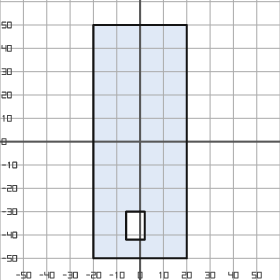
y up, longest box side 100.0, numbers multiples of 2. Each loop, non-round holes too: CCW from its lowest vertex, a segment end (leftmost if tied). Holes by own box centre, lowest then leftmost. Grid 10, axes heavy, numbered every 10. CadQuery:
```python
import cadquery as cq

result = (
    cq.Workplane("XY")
    .moveTo(-20.0, -50.0)
    .lineTo(20.0, -50.0)
    .lineTo(20.0, 50.0)
    .lineTo(-20.0, 50.0)
    .close()
    .moveTo(-6.0, -42.0)
    .lineTo(2.0, -42.0)
    .lineTo(2.0, -30.0)
    .lineTo(-6.0, -30.0)
    .close()
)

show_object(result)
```